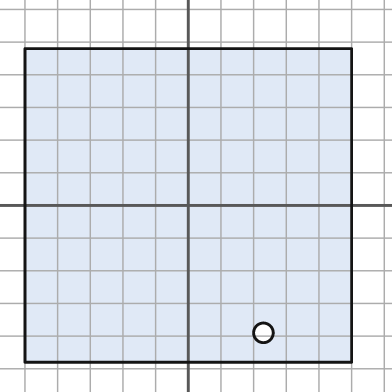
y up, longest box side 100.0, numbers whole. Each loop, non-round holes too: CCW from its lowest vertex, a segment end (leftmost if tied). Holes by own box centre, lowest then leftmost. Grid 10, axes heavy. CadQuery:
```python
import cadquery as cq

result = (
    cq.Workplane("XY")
    .moveTo(-50.0, -48.0)
    .lineTo(50.0, -48.0)
    .lineTo(50.0, 48.0)
    .lineTo(-50.0, 48.0)
    .close()
    .moveTo(23.0, -39.0)
    .circle(3.0)
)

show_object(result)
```